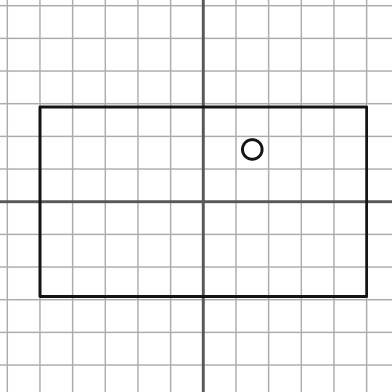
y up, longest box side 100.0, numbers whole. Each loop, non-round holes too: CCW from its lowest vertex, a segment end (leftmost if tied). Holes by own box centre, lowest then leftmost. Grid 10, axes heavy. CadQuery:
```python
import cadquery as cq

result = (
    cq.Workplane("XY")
    .moveTo(-50.0, -29.0)
    .lineTo(50.0, -29.0)
    .lineTo(50.0, 29.0)
    .lineTo(-50.0, 29.0)
    .close()
    .moveTo(15.0, 16.0)
    .circle(3.0)
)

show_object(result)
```